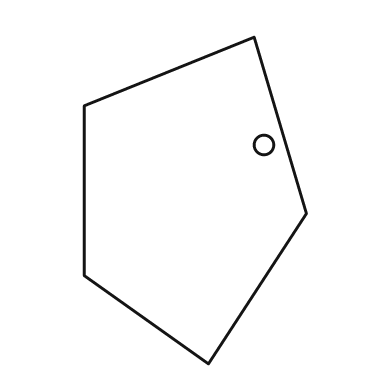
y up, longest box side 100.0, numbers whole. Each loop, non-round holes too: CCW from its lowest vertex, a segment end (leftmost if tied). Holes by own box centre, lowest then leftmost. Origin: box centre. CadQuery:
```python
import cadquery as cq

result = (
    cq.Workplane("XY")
    .moveTo(4.0, -50.0)
    .lineTo(34.0, -4.0)
    .lineTo(18.0, 50.0)
    .lineTo(-34.0, 29.0)
    .lineTo(-34.0, -23.0)
    .close()
    .moveTo(21.0, 17.0)
    .circle(3.0)
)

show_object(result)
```